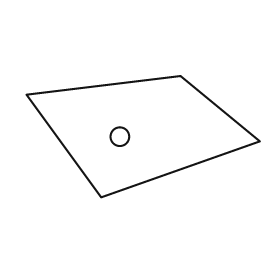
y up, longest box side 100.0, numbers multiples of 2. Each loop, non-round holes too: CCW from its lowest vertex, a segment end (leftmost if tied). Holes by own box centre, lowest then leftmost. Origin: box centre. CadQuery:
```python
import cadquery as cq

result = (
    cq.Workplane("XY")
    .moveTo(-18.0, -26.0)
    .lineTo(50.0, -2.0)
    .lineTo(16.0, 26.0)
    .lineTo(-50.0, 18.0)
    .close()
    .moveTo(-10.0, 0.0)
    .circle(4.0)
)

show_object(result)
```